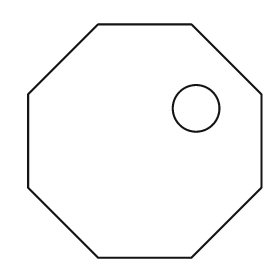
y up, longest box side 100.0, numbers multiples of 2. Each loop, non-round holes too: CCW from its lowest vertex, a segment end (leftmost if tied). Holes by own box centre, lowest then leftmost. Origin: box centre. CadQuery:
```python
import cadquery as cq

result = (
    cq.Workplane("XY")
    .moveTo(-20.0, -50.0)
    .lineTo(20.0, -50.0)
    .lineTo(50.0, -20.0)
    .lineTo(50.0, 20.0)
    .lineTo(20.0, 50.0)
    .lineTo(-20.0, 50.0)
    .lineTo(-50.0, 20.0)
    .lineTo(-50.0, -20.0)
    .close()
    .moveTo(22.0, 14.0)
    .circle(10.0)
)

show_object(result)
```